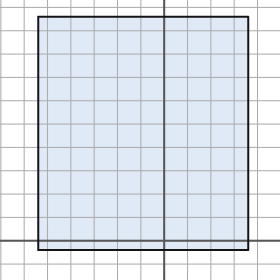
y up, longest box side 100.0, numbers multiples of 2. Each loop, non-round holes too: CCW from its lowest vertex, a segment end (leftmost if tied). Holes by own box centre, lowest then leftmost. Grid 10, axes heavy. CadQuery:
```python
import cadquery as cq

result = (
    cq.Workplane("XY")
    .moveTo(-54.0, -4.0)
    .lineTo(36.0, -4.0)
    .lineTo(36.0, 96.0)
    .lineTo(-54.0, 96.0)
    .close()
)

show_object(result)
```